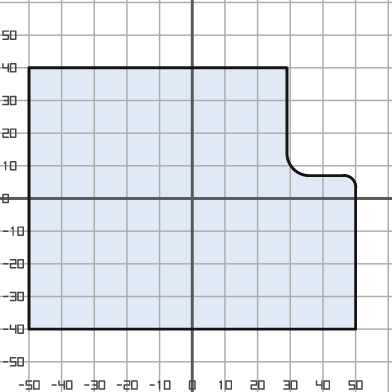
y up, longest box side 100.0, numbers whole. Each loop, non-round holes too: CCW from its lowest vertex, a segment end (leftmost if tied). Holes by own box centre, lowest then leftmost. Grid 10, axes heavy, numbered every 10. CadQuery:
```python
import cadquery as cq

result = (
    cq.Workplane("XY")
    .moveTo(-50.0, -40.0)
    .lineTo(50.0, -40.0)
    .lineTo(50.0, 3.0)
    .threePointArc((49.0, 6.0), (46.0, 7.0))
    .lineTo(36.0, 7.0)
    .threePointArc((31.0, 9.0), (29.0, 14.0))
    .lineTo(29.0, 40.0)
    .lineTo(-50.0, 40.0)
    .close()
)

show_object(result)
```